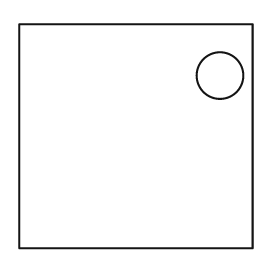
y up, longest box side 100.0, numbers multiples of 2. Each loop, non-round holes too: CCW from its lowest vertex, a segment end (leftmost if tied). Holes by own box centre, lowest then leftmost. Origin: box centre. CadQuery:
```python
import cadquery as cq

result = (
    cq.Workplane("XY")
    .moveTo(-50.0, -48.0)
    .lineTo(50.0, -48.0)
    .lineTo(50.0, 48.0)
    .lineTo(-50.0, 48.0)
    .close()
    .moveTo(36.0, 26.0)
    .circle(10.0)
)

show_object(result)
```